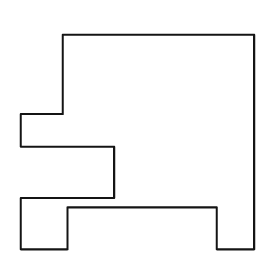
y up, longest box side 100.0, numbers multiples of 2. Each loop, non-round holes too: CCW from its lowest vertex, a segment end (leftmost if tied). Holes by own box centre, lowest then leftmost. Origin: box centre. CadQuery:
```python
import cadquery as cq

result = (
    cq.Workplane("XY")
    .moveTo(-50.0, -46.0)
    .lineTo(-30.0, -46.0)
    .lineTo(-30.0, -28.0)
    .lineTo(34.0, -28.0)
    .lineTo(34.0, -46.0)
    .lineTo(50.0, -46.0)
    .lineTo(50.0, 46.0)
    .lineTo(-32.0, 46.0)
    .lineTo(-32.0, 12.0)
    .lineTo(-50.0, 12.0)
    .lineTo(-50.0, -2.0)
    .lineTo(-10.0, -2.0)
    .lineTo(-10.0, -24.0)
    .lineTo(-50.0, -24.0)
    .close()
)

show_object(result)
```